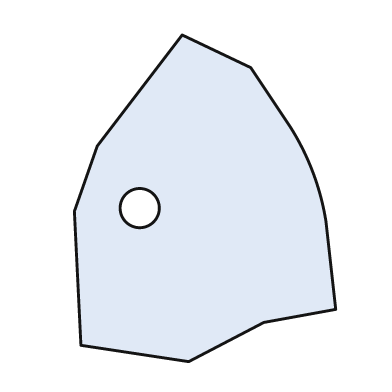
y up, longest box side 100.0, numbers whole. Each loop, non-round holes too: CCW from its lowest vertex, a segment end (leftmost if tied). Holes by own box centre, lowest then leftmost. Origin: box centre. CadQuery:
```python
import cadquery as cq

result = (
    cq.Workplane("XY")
    .moveTo(-5.0, -50.0)
    .lineTo(18.0, -38.0)
    .lineTo(40.0, -34.0)
    .lineTo(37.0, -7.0)
    .threePointArc((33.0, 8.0), (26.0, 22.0))
    .lineTo(14.0, 40.0)
    .lineTo(-7.0, 50.0)
    .lineTo(-33.0, 16.0)
    .lineTo(-40.0, -4.0)
    .lineTo(-38.0, -45.0)
    .close()
    .moveTo(-20.0, -3.0)
    .circle(6.0)
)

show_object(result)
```